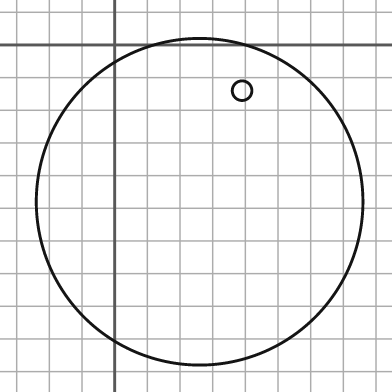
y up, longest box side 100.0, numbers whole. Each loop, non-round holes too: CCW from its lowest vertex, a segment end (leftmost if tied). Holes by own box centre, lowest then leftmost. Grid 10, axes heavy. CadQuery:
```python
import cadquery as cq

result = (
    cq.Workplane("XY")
    .moveTo(26.0, -48.0)
    .circle(50.0)
    .moveTo(39.0, -14.0)
    .circle(3.0)
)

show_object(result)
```